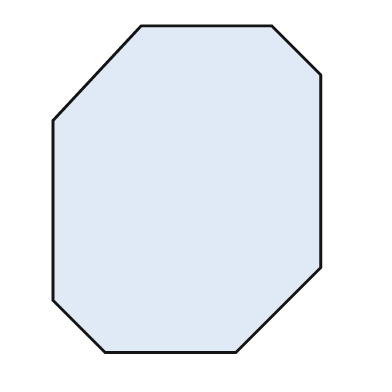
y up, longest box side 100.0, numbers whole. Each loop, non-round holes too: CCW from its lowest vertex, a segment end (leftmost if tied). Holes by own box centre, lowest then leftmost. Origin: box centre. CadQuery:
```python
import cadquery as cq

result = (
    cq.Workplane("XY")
    .moveTo(-25.0, -50.0)
    .lineTo(15.0, -50.0)
    .lineTo(41.0, -24.0)
    .lineTo(41.0, 35.0)
    .lineTo(26.0, 50.0)
    .lineTo(-14.0, 50.0)
    .lineTo(-41.0, 21.0)
    .lineTo(-41.0, -34.0)
    .close()
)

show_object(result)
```